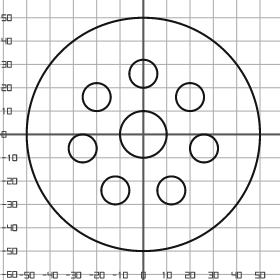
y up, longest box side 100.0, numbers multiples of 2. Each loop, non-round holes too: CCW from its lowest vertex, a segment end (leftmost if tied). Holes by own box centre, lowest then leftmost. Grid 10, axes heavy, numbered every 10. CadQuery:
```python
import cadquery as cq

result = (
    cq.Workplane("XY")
    .moveTo(0.0, 0.0)
    .circle(50.0)
    .moveTo(-12.0, -24.0)
    .circle(6.0)
    .moveTo(12.0, -24.0)
    .circle(6.0)
    .moveTo(-26.0, -6.0)
    .circle(6.0)
    .moveTo(26.0, -6.0)
    .circle(6.0)
    .moveTo(0.0, 0.0)
    .circle(10.0)
    .moveTo(-20.0, 16.0)
    .circle(6.0)
    .moveTo(20.0, 16.0)
    .circle(6.0)
    .moveTo(0.0, 26.0)
    .circle(6.0)
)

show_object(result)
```